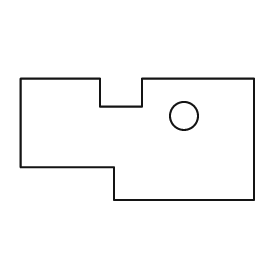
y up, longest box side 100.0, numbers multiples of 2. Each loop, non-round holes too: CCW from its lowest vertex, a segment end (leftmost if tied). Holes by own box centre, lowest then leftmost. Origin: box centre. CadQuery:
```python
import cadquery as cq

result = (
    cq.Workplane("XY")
    .moveTo(-10.0, -26.0)
    .lineTo(50.0, -26.0)
    .lineTo(50.0, 26.0)
    .lineTo(2.0, 26.0)
    .lineTo(2.0, 14.0)
    .lineTo(-16.0, 14.0)
    .lineTo(-16.0, 26.0)
    .lineTo(-50.0, 26.0)
    .lineTo(-50.0, -12.0)
    .lineTo(-10.0, -12.0)
    .close()
    .moveTo(20.0, 10.0)
    .circle(6.0)
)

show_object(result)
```